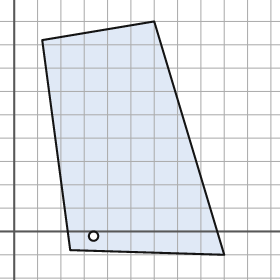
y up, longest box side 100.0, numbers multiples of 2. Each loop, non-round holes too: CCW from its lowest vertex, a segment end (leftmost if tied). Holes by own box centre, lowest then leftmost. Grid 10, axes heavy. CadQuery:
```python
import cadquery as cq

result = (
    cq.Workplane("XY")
    .moveTo(90.0, -10.0)
    .lineTo(60.0, 90.0)
    .lineTo(12.0, 82.0)
    .lineTo(24.0, -8.0)
    .close()
    .moveTo(34.0, -2.0)
    .circle(2.0)
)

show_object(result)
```